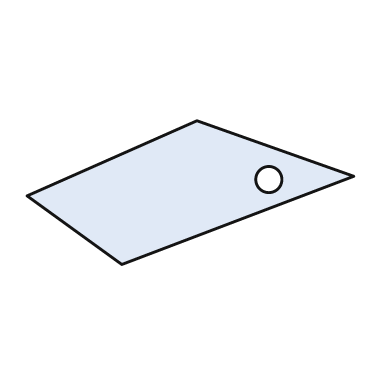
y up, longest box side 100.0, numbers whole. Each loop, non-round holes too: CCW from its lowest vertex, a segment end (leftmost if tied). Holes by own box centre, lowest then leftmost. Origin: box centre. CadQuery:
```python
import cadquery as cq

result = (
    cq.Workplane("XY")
    .moveTo(-21.0, -22.0)
    .lineTo(50.0, 5.0)
    .lineTo(2.0, 22.0)
    .lineTo(-50.0, -1.0)
    .close()
    .moveTo(24.0, 4.0)
    .circle(4.0)
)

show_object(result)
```